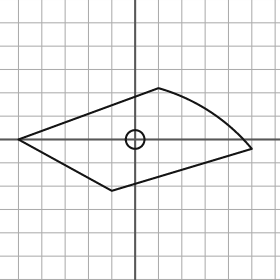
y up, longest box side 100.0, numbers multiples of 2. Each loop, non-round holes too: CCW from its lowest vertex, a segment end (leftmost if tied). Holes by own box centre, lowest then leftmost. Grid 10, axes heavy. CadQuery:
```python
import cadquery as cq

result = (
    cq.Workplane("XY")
    .moveTo(-10.0, -22.0)
    .lineTo(50.0, -4.0)
    .threePointArc((32.0, 12.0), (10.0, 22.0))
    .lineTo(-50.0, 0.0)
    .close()
    .moveTo(0.0, 0.0)
    .circle(4.0)
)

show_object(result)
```